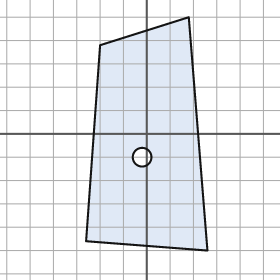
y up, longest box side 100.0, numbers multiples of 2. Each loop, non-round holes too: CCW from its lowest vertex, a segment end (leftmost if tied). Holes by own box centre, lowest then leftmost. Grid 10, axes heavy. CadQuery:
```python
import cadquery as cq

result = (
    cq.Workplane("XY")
    .moveTo(26.0, -50.0)
    .lineTo(18.0, 50.0)
    .lineTo(-20.0, 38.0)
    .lineTo(-26.0, -46.0)
    .close()
    .moveTo(-2.0, -10.0)
    .circle(4.0)
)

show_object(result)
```